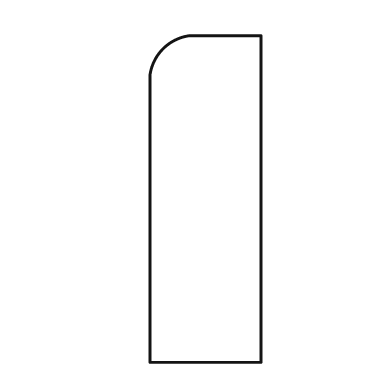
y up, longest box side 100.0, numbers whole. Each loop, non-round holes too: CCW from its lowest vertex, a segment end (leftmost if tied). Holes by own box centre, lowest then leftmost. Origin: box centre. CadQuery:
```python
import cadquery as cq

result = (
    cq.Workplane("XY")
    .moveTo(-17.0, -50.0)
    .lineTo(17.0, -50.0)
    .lineTo(17.0, 50.0)
    .lineTo(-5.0, 50.0)
    .threePointArc((-13.0, 46.0), (-17.0, 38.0))
    .close()
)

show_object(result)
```